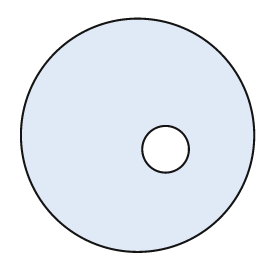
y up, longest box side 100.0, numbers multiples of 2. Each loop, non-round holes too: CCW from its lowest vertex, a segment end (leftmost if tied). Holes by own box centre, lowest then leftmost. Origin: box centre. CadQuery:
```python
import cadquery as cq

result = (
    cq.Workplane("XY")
    .moveTo(0.0, 0.0)
    .circle(50.0)
    .moveTo(12.0, -6.0)
    .circle(10.0)
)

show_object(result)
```